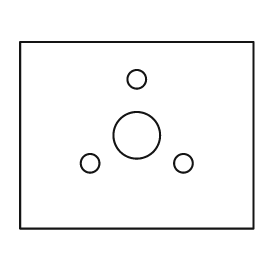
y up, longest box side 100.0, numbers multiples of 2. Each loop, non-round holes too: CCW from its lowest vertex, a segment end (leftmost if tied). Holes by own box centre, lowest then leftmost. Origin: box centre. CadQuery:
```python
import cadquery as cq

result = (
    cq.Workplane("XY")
    .moveTo(-50.0, -40.0)
    .lineTo(50.0, -40.0)
    .lineTo(50.0, 40.0)
    .lineTo(-50.0, 40.0)
    .close()
    .moveTo(-20.0, -12.0)
    .circle(4.0)
    .moveTo(20.0, -12.0)
    .circle(4.0)
    .moveTo(0.0, 0.0)
    .circle(10.0)
    .moveTo(0.0, 24.0)
    .circle(4.0)
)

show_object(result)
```